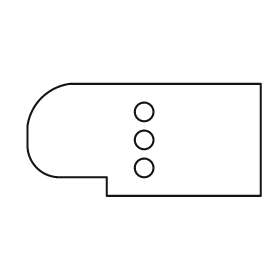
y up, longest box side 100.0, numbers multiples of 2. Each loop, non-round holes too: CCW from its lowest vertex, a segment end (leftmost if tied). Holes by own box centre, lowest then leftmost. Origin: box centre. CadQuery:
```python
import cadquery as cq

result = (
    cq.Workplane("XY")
    .moveTo(-16.0, -24.0)
    .lineTo(50.0, -24.0)
    .lineTo(50.0, 24.0)
    .lineTo(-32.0, 24.0)
    .threePointArc((-44.0, 18.0), (-50.0, 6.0))
    .lineTo(-50.0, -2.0)
    .threePointArc((-46.0, -12.0), (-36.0, -16.0))
    .lineTo(-16.0, -16.0)
    .close()
    .moveTo(0.0, -12.0)
    .circle(4.0)
    .moveTo(0.0, 0.0)
    .circle(4.0)
    .moveTo(0.0, 12.0)
    .circle(4.0)
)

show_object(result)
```